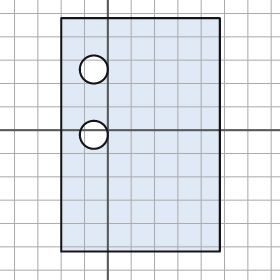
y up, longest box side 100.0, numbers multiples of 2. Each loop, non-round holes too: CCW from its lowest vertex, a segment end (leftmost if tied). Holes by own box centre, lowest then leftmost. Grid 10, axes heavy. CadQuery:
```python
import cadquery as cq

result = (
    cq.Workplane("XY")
    .moveTo(-20.0, -52.0)
    .lineTo(48.0, -52.0)
    .lineTo(48.0, 48.0)
    .lineTo(-20.0, 48.0)
    .close()
    .moveTo(-6.0, -2.0)
    .circle(6.0)
    .moveTo(-6.0, 26.0)
    .circle(6.0)
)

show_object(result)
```